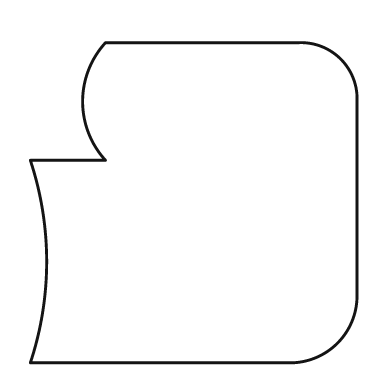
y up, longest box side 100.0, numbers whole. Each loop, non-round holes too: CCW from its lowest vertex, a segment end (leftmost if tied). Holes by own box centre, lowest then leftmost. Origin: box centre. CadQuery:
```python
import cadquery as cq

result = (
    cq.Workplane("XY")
    .moveTo(-50.0, -49.0)
    .lineTo(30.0, -49.0)
    .threePointArc((44.0, -43.0), (50.0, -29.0))
    .lineTo(50.0, 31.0)
    .threePointArc((45.0, 44.0), (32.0, 49.0))
    .lineTo(-27.0, 49.0)
    .threePointArc((-34.0, 31.0), (-27.0, 13.0))
    .lineTo(-50.0, 13.0)
    .threePointArc((-45.0, -18.0), (-50.0, -49.0))
    .close()
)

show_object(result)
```